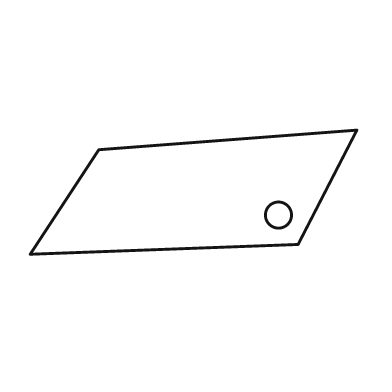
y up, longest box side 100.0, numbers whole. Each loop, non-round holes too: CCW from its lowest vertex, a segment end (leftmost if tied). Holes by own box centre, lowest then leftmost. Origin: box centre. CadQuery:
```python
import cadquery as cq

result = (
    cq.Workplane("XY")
    .moveTo(-50.0, -19.0)
    .lineTo(32.0, -16.0)
    .lineTo(50.0, 19.0)
    .lineTo(-29.0, 13.0)
    .close()
    .moveTo(26.0, -7.0)
    .circle(4.0)
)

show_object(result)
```